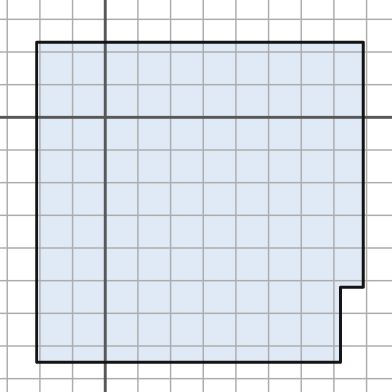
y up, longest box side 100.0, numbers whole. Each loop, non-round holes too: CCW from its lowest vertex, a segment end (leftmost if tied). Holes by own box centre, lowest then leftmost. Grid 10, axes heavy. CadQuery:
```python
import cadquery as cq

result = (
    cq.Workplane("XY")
    .moveTo(-21.0, -75.0)
    .lineTo(72.0, -75.0)
    .lineTo(72.0, -52.0)
    .lineTo(79.0, -52.0)
    .lineTo(79.0, 23.0)
    .lineTo(-21.0, 23.0)
    .close()
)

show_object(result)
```